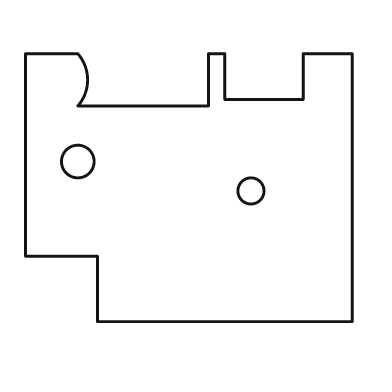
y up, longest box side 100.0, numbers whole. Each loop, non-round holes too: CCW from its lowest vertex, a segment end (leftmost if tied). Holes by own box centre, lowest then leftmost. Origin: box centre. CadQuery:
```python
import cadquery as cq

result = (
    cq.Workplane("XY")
    .moveTo(-28.0, -41.0)
    .lineTo(50.0, -41.0)
    .lineTo(50.0, 41.0)
    .lineTo(35.0, 41.0)
    .lineTo(35.0, 27.0)
    .lineTo(11.0, 27.0)
    .lineTo(11.0, 41.0)
    .lineTo(6.0, 41.0)
    .lineTo(6.0, 25.0)
    .lineTo(-34.0, 25.0)
    .threePointArc((-31.0, 33.0), (-34.0, 41.0))
    .lineTo(-50.0, 41.0)
    .lineTo(-50.0, -21.0)
    .lineTo(-28.0, -21.0)
    .close()
    .moveTo(19.0, -1.0)
    .circle(4.0)
    .moveTo(-34.0, 8.0)
    .circle(5.0)
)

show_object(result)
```